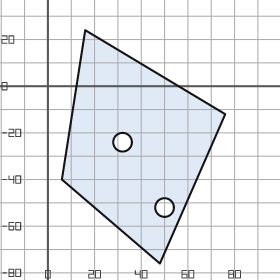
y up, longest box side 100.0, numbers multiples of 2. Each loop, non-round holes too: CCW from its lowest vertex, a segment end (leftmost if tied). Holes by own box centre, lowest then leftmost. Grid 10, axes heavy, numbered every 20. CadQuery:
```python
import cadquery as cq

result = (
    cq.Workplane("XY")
    .moveTo(48.0, -76.0)
    .lineTo(76.0, -12.0)
    .lineTo(16.0, 24.0)
    .lineTo(6.0, -40.0)
    .close()
    .moveTo(50.0, -52.0)
    .circle(4.0)
    .moveTo(32.0, -24.0)
    .circle(4.0)
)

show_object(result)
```